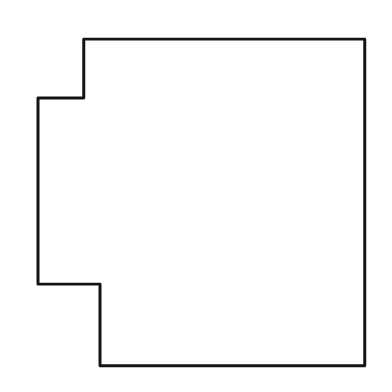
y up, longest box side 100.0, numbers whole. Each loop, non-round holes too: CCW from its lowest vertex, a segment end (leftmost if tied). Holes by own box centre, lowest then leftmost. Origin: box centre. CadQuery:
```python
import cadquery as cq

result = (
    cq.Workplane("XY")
    .moveTo(-31.0, -50.0)
    .lineTo(50.0, -50.0)
    .lineTo(50.0, 50.0)
    .lineTo(-36.0, 50.0)
    .lineTo(-36.0, 32.0)
    .lineTo(-50.0, 32.0)
    .lineTo(-50.0, -25.0)
    .lineTo(-31.0, -25.0)
    .close()
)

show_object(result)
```